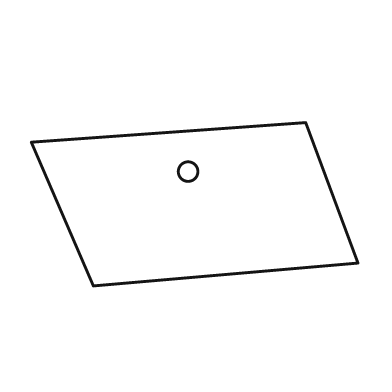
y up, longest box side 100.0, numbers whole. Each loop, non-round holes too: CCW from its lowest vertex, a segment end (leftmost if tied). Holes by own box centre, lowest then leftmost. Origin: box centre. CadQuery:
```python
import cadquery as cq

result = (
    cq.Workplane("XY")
    .moveTo(-31.0, -25.0)
    .lineTo(50.0, -18.0)
    .lineTo(34.0, 25.0)
    .lineTo(-50.0, 19.0)
    .close()
    .moveTo(-2.0, 10.0)
    .circle(3.0)
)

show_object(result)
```